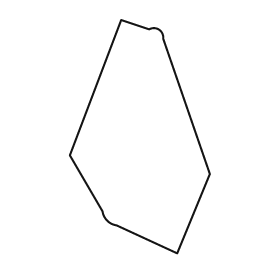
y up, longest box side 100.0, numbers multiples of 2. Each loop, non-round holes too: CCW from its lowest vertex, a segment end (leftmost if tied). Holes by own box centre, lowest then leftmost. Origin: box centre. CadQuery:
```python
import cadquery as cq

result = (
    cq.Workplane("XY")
    .moveTo(16.0, -50.0)
    .lineTo(30.0, -16.0)
    .lineTo(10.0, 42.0)
    .threePointArc((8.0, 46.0), (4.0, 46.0))
    .lineTo(-8.0, 50.0)
    .lineTo(-30.0, -8.0)
    .lineTo(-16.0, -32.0)
    .threePointArc((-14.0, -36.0), (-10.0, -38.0))
    .close()
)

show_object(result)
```